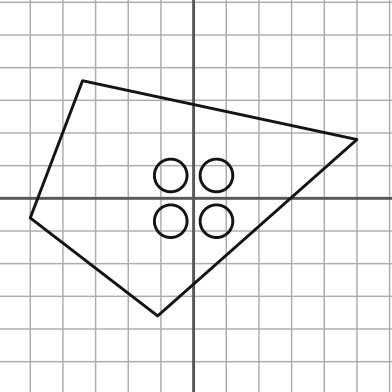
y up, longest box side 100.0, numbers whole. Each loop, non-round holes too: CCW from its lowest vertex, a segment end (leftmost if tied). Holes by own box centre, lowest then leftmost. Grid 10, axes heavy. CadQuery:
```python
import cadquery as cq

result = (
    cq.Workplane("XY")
    .moveTo(-11.0, -36.0)
    .lineTo(50.0, 18.0)
    .lineTo(-34.0, 36.0)
    .lineTo(-50.0, -6.0)
    .close()
    .moveTo(-7.0, -7.0)
    .circle(5.0)
    .moveTo(7.0, -7.0)
    .circle(5.0)
    .moveTo(-7.0, 7.0)
    .circle(5.0)
    .moveTo(7.0, 7.0)
    .circle(5.0)
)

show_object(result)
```